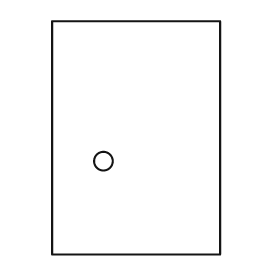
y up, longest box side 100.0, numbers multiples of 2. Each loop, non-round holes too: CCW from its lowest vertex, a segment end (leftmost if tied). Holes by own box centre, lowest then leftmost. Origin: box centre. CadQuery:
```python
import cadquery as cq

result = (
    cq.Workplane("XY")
    .moveTo(-36.0, -50.0)
    .lineTo(36.0, -50.0)
    .lineTo(36.0, 50.0)
    .lineTo(-36.0, 50.0)
    .close()
    .moveTo(-14.0, -10.0)
    .circle(4.0)
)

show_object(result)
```